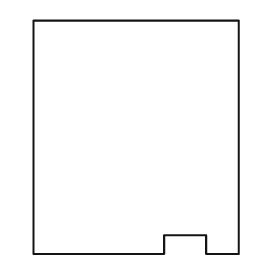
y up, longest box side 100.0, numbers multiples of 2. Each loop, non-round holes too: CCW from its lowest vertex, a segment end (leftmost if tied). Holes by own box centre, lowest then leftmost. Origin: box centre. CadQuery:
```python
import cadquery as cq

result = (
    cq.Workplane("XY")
    .moveTo(-44.0, -50.0)
    .lineTo(12.0, -50.0)
    .lineTo(12.0, -42.0)
    .lineTo(30.0, -42.0)
    .lineTo(30.0, -50.0)
    .lineTo(44.0, -50.0)
    .lineTo(44.0, 50.0)
    .lineTo(-44.0, 50.0)
    .close()
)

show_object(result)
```